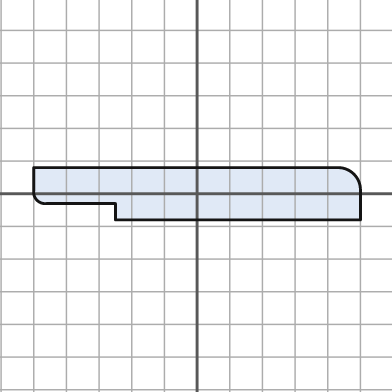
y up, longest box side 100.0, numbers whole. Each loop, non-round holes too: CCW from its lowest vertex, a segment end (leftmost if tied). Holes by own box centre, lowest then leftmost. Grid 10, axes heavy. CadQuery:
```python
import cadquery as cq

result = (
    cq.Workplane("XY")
    .moveTo(-25.0, -8.0)
    .lineTo(50.0, -8.0)
    .lineTo(50.0, 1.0)
    .threePointArc((48.0, 6.0), (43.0, 8.0))
    .lineTo(-50.0, 8.0)
    .lineTo(-50.0, 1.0)
    .threePointArc((-49.0, -2.0), (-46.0, -3.0))
    .lineTo(-25.0, -3.0)
    .close()
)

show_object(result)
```